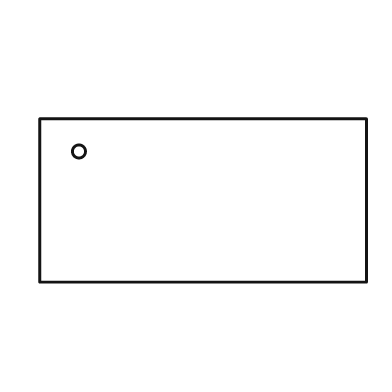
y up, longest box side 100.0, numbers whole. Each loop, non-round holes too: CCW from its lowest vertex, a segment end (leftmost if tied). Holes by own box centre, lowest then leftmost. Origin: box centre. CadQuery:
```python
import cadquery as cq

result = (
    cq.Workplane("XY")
    .moveTo(-50.0, -25.0)
    .lineTo(50.0, -25.0)
    .lineTo(50.0, 25.0)
    .lineTo(-50.0, 25.0)
    .close()
    .moveTo(-38.0, 15.0)
    .circle(2.0)
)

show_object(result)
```